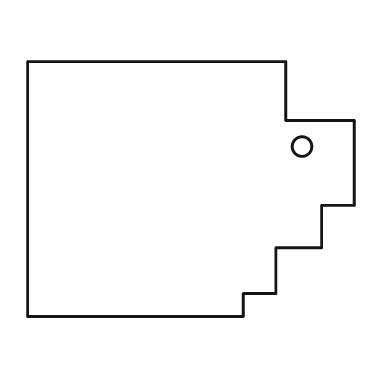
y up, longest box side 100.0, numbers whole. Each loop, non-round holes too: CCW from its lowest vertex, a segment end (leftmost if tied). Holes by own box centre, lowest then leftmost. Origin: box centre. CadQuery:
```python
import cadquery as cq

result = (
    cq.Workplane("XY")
    .moveTo(-50.0, -39.0)
    .lineTo(16.0, -39.0)
    .lineTo(16.0, -32.0)
    .lineTo(26.0, -32.0)
    .lineTo(26.0, -18.0)
    .lineTo(40.0, -18.0)
    .lineTo(40.0, -5.0)
    .lineTo(50.0, -5.0)
    .lineTo(50.0, 21.0)
    .lineTo(29.0, 21.0)
    .lineTo(29.0, 39.0)
    .lineTo(-50.0, 39.0)
    .close()
    .moveTo(34.0, 13.0)
    .circle(3.0)
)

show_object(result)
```